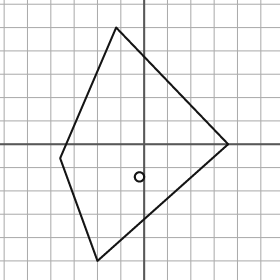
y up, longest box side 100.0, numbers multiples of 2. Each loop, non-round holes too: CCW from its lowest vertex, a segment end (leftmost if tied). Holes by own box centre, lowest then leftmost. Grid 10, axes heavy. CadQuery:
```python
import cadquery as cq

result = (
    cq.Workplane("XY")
    .moveTo(-20.0, -50.0)
    .lineTo(36.0, 0.0)
    .lineTo(-12.0, 50.0)
    .lineTo(-36.0, -6.0)
    .close()
    .moveTo(-2.0, -14.0)
    .circle(2.0)
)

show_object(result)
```